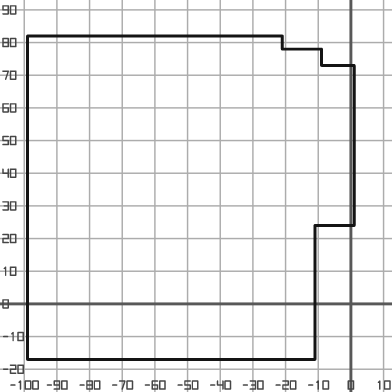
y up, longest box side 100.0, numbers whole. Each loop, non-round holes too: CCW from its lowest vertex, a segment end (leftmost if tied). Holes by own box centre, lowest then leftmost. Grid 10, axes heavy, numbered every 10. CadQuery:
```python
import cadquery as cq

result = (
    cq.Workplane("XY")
    .moveTo(-99.0, -17.0)
    .lineTo(-11.0, -17.0)
    .lineTo(-11.0, 24.0)
    .lineTo(1.0, 24.0)
    .lineTo(1.0, 73.0)
    .lineTo(-9.0, 73.0)
    .lineTo(-9.0, 78.0)
    .lineTo(-21.0, 78.0)
    .lineTo(-21.0, 82.0)
    .lineTo(-99.0, 82.0)
    .close()
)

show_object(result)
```